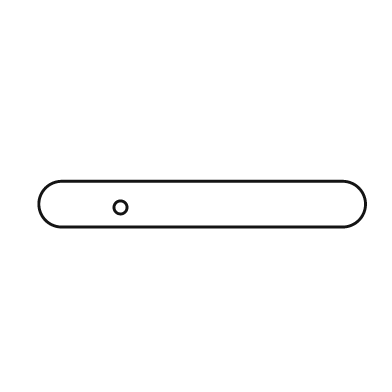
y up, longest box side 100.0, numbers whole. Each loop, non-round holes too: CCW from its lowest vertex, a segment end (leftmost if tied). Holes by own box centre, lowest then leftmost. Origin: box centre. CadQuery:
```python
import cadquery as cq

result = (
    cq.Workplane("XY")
    .moveTo(-43.0, -7.0)
    .lineTo(43.0, -7.0)
    .threePointArc((50.0, 0.0), (43.0, 7.0))
    .lineTo(-43.0, 7.0)
    .threePointArc((-50.0, 0.0), (-43.0, -7.0))
    .close()
    .moveTo(-25.0, -1.0)
    .circle(2.0)
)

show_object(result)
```